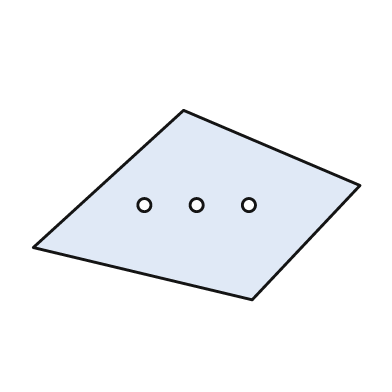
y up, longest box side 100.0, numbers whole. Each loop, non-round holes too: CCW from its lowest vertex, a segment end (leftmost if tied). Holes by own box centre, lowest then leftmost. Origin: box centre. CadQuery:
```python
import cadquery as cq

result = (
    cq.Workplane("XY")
    .moveTo(17.0, -29.0)
    .lineTo(50.0, 6.0)
    .lineTo(-4.0, 29.0)
    .lineTo(-50.0, -13.0)
    .close()
    .moveTo(-16.0, 0.0)
    .circle(2.0)
    .moveTo(0.0, 0.0)
    .circle(2.0)
    .moveTo(16.0, 0.0)
    .circle(2.0)
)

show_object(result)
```